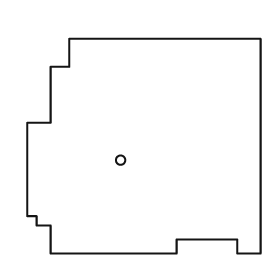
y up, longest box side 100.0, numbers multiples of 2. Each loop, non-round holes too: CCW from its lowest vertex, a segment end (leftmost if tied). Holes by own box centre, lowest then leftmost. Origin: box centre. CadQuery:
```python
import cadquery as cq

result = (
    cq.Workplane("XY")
    .moveTo(-40.0, -46.0)
    .lineTo(14.0, -46.0)
    .lineTo(14.0, -40.0)
    .lineTo(40.0, -40.0)
    .lineTo(40.0, -46.0)
    .lineTo(50.0, -46.0)
    .lineTo(50.0, 46.0)
    .lineTo(-32.0, 46.0)
    .lineTo(-32.0, 34.0)
    .lineTo(-40.0, 34.0)
    .lineTo(-40.0, 10.0)
    .lineTo(-50.0, 10.0)
    .lineTo(-50.0, -30.0)
    .lineTo(-46.0, -30.0)
    .lineTo(-46.0, -34.0)
    .lineTo(-40.0, -34.0)
    .close()
    .moveTo(-10.0, -6.0)
    .circle(2.0)
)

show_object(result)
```